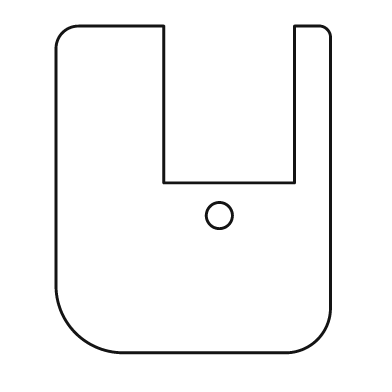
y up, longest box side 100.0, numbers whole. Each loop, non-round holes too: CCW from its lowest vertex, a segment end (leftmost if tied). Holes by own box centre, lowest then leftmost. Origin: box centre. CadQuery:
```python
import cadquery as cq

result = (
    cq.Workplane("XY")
    .moveTo(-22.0, -50.0)
    .lineTo(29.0, -50.0)
    .threePointArc((38.0, -46.0), (42.0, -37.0))
    .lineTo(42.0, 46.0)
    .threePointArc((41.0, 49.0), (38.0, 50.0))
    .lineTo(31.0, 50.0)
    .lineTo(31.0, 2.0)
    .lineTo(-9.0, 2.0)
    .lineTo(-9.0, 50.0)
    .lineTo(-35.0, 50.0)
    .threePointArc((-40.0, 48.0), (-42.0, 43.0))
    .lineTo(-42.0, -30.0)
    .threePointArc((-36.0, -44.0), (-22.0, -50.0))
    .close()
    .moveTo(8.0, -8.0)
    .circle(4.0)
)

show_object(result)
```